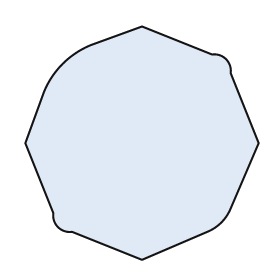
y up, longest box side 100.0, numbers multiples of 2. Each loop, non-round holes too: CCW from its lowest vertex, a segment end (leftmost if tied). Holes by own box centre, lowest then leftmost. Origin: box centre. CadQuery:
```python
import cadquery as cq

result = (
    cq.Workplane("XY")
    .moveTo(0.0, -50.0)
    .lineTo(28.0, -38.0)
    .threePointArc((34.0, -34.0), (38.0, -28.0))
    .lineTo(50.0, 0.0)
    .lineTo(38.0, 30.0)
    .threePointArc((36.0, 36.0), (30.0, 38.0))
    .lineTo(0.0, 50.0)
    .lineTo(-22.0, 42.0)
    .threePointArc((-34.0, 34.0), (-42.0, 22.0))
    .lineTo(-50.0, 0.0)
    .lineTo(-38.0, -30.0)
    .threePointArc((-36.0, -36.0), (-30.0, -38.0))
    .close()
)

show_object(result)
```